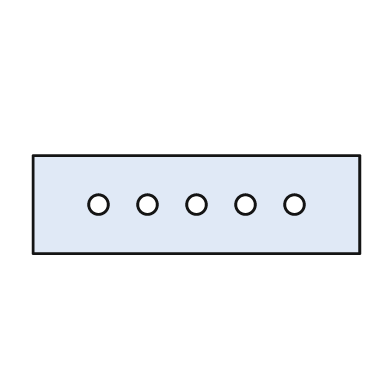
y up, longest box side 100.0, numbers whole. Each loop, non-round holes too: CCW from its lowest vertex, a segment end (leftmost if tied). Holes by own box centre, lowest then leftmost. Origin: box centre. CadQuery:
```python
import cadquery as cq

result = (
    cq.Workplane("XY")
    .moveTo(-50.0, -15.0)
    .lineTo(50.0, -15.0)
    .lineTo(50.0, 15.0)
    .lineTo(-50.0, 15.0)
    .close()
    .moveTo(-30.0, 0.0)
    .circle(3.0)
    .moveTo(-15.0, 0.0)
    .circle(3.0)
    .moveTo(0.0, 0.0)
    .circle(3.0)
    .moveTo(15.0, 0.0)
    .circle(3.0)
    .moveTo(30.0, 0.0)
    .circle(3.0)
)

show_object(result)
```